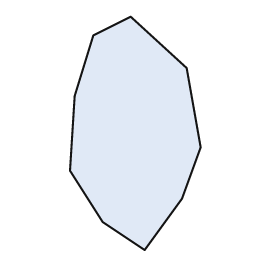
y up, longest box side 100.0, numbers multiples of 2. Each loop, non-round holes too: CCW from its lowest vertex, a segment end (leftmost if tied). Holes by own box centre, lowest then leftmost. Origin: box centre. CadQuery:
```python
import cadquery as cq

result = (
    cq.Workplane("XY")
    .moveTo(4.0, -50.0)
    .lineTo(20.0, -28.0)
    .lineTo(28.0, -6.0)
    .lineTo(22.0, 28.0)
    .lineTo(-2.0, 50.0)
    .lineTo(-18.0, 42.0)
    .lineTo(-26.0, 16.0)
    .lineTo(-28.0, -16.0)
    .lineTo(-14.0, -38.0)
    .close()
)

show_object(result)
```